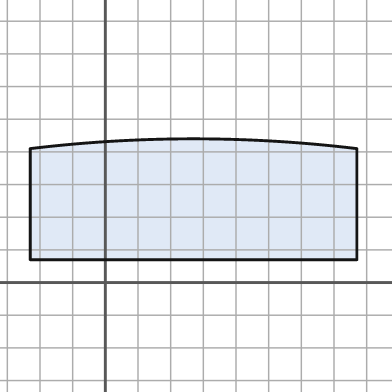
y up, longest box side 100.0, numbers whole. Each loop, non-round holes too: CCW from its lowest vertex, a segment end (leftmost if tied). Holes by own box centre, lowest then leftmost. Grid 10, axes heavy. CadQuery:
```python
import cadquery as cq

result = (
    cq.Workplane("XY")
    .moveTo(-23.0, 7.0)
    .lineTo(77.0, 7.0)
    .lineTo(77.0, 41.0)
    .threePointArc((27.0, 44.0), (-23.0, 41.0))
    .close()
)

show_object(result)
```